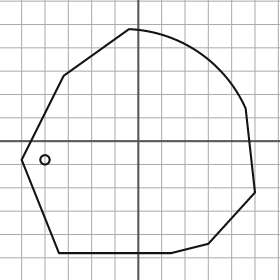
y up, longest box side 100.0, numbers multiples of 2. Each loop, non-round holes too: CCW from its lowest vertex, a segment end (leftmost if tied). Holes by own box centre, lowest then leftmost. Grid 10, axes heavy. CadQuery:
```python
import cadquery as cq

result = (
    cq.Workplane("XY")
    .moveTo(-34.0, -48.0)
    .lineTo(14.0, -48.0)
    .lineTo(30.0, -44.0)
    .lineTo(50.0, -22.0)
    .lineTo(46.0, 14.0)
    .threePointArc((26.0, 38.0), (-4.0, 48.0))
    .lineTo(-32.0, 28.0)
    .lineTo(-50.0, -8.0)
    .close()
    .moveTo(-40.0, -8.0)
    .circle(2.0)
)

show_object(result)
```